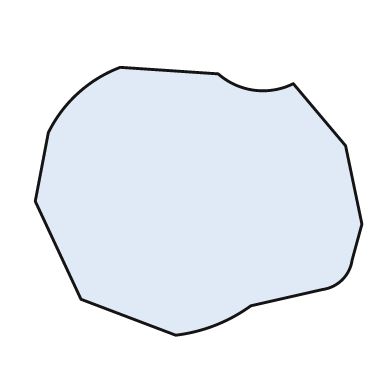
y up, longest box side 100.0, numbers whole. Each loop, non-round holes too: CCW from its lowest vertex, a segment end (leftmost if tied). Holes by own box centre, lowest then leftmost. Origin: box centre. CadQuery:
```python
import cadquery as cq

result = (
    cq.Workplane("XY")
    .moveTo(-7.0, -41.0)
    .threePointArc((5.0, -38.0), (16.0, -32.0))
    .lineTo(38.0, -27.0)
    .threePointArc((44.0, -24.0), (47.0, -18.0))
    .lineTo(50.0, -7.0)
    .lineTo(45.0, 17.0)
    .lineTo(29.0, 36.0)
    .threePointArc((17.0, 34.0), (6.0, 39.0))
    .lineTo(-24.0, 41.0)
    .threePointArc((-37.0, 33.0), (-46.0, 21.0))
    .lineTo(-50.0, 0.0)
    .lineTo(-36.0, -30.0)
    .close()
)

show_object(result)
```